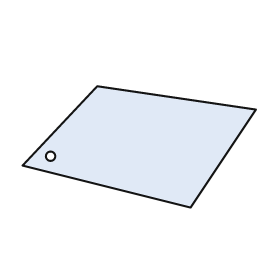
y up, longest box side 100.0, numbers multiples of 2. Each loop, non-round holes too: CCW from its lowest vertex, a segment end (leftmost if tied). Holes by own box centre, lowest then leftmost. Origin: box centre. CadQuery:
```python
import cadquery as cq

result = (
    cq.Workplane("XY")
    .moveTo(22.0, -26.0)
    .lineTo(50.0, 16.0)
    .lineTo(-18.0, 26.0)
    .lineTo(-50.0, -8.0)
    .close()
    .moveTo(-38.0, -4.0)
    .circle(2.0)
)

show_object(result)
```